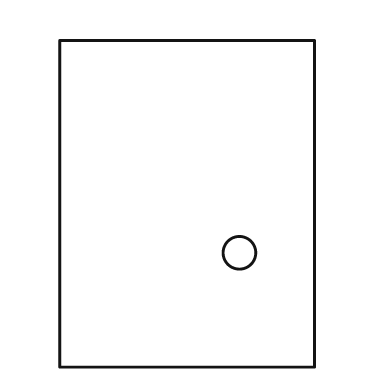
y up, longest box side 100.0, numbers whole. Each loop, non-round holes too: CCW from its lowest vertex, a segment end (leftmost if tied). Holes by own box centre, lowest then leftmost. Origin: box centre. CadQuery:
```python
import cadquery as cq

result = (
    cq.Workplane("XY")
    .moveTo(-39.0, -50.0)
    .lineTo(39.0, -50.0)
    .lineTo(39.0, 50.0)
    .lineTo(-39.0, 50.0)
    .close()
    .moveTo(16.0, -15.0)
    .circle(5.0)
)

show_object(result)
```